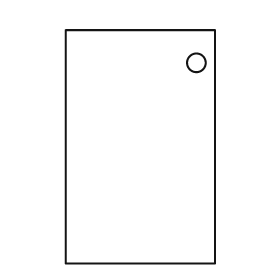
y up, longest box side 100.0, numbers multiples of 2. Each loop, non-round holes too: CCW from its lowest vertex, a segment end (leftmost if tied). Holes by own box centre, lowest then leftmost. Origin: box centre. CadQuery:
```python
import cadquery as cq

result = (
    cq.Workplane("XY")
    .moveTo(-32.0, -50.0)
    .lineTo(32.0, -50.0)
    .lineTo(32.0, 50.0)
    .lineTo(-32.0, 50.0)
    .close()
    .moveTo(24.0, 36.0)
    .circle(4.0)
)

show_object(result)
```